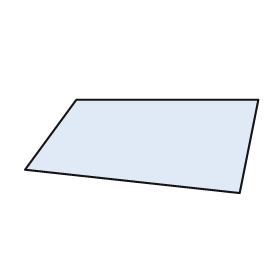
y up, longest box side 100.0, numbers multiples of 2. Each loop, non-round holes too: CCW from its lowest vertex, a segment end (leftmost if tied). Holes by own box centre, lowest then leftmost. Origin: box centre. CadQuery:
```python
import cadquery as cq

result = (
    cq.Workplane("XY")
    .moveTo(42.0, -20.0)
    .lineTo(50.0, 20.0)
    .lineTo(-28.0, 20.0)
    .lineTo(-50.0, -10.0)
    .close()
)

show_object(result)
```